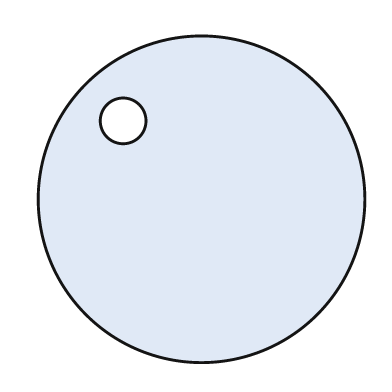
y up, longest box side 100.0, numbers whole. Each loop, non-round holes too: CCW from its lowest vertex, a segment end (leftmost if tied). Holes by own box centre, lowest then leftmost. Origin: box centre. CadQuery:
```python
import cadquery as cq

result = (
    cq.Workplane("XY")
    .moveTo(0.0, 0.0)
    .circle(50.0)
    .moveTo(-24.0, 24.0)
    .circle(7.0)
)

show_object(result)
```